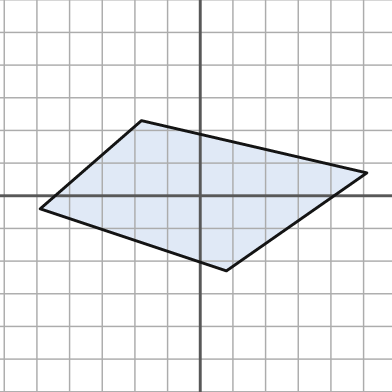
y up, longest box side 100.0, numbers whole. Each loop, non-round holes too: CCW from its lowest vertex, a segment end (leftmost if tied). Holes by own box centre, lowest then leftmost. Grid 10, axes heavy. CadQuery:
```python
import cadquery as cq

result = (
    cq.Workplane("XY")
    .moveTo(8.0, -23.0)
    .lineTo(51.0, 7.0)
    .lineTo(-18.0, 23.0)
    .lineTo(-49.0, -4.0)
    .close()
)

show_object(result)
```